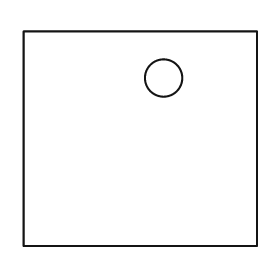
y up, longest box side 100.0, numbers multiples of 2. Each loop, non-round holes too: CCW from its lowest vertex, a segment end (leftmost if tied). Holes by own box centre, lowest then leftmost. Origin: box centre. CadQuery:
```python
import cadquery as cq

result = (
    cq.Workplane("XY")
    .moveTo(-50.0, -46.0)
    .lineTo(50.0, -46.0)
    .lineTo(50.0, 46.0)
    .lineTo(-50.0, 46.0)
    .close()
    .moveTo(10.0, 26.0)
    .circle(8.0)
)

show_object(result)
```